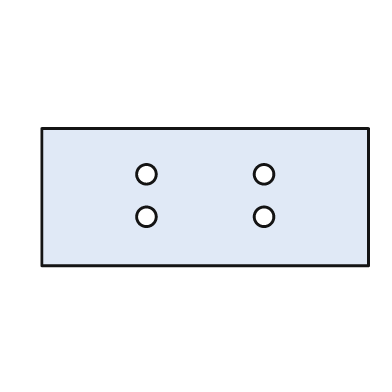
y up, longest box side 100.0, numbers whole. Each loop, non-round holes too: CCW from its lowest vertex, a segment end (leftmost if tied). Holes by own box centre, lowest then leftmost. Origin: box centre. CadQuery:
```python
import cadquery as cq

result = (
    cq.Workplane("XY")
    .moveTo(-50.0, -21.0)
    .lineTo(50.0, -21.0)
    .lineTo(50.0, 21.0)
    .lineTo(-50.0, 21.0)
    .close()
    .moveTo(-18.0, -6.0)
    .circle(3.0)
    .moveTo(18.0, -6.0)
    .circle(3.0)
    .moveTo(-18.0, 7.0)
    .circle(3.0)
    .moveTo(18.0, 7.0)
    .circle(3.0)
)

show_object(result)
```